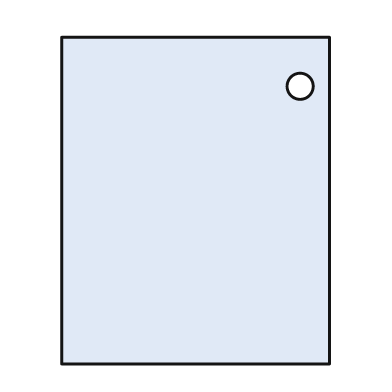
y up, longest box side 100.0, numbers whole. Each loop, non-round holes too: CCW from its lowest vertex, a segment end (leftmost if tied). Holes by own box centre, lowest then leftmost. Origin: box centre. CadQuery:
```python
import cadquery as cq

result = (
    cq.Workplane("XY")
    .moveTo(-41.0, -50.0)
    .lineTo(41.0, -50.0)
    .lineTo(41.0, 50.0)
    .lineTo(-41.0, 50.0)
    .close()
    .moveTo(32.0, 35.0)
    .circle(4.0)
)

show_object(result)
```